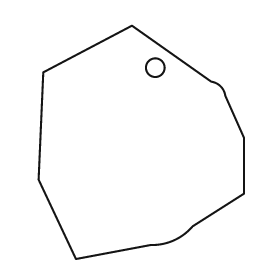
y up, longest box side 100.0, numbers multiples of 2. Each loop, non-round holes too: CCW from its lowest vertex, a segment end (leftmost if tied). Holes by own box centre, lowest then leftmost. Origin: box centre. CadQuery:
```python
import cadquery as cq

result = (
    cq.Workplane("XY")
    .moveTo(-28.0, -50.0)
    .lineTo(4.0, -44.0)
    .threePointArc((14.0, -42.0), (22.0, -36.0))
    .lineTo(44.0, -22.0)
    .lineTo(44.0, 2.0)
    .lineTo(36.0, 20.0)
    .threePointArc((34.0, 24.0), (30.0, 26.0))
    .lineTo(-4.0, 50.0)
    .lineTo(-42.0, 30.0)
    .lineTo(-44.0, -16.0)
    .close()
    .moveTo(6.0, 32.0)
    .circle(4.0)
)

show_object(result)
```